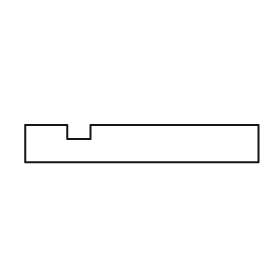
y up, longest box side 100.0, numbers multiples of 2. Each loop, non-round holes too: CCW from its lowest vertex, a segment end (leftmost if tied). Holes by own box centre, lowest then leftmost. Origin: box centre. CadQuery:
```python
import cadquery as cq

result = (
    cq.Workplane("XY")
    .moveTo(-50.0, -8.0)
    .lineTo(50.0, -8.0)
    .lineTo(50.0, 8.0)
    .lineTo(-22.0, 8.0)
    .lineTo(-22.0, 2.0)
    .lineTo(-32.0, 2.0)
    .lineTo(-32.0, 8.0)
    .lineTo(-50.0, 8.0)
    .close()
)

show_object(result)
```